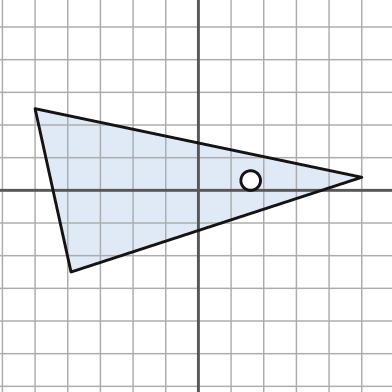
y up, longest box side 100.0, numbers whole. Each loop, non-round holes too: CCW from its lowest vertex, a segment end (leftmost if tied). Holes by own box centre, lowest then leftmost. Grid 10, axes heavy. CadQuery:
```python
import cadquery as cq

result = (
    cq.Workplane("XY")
    .moveTo(-39.0, -25.0)
    .lineTo(50.0, 4.0)
    .lineTo(-50.0, 25.0)
    .close()
    .moveTo(16.0, 3.0)
    .circle(3.0)
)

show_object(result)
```